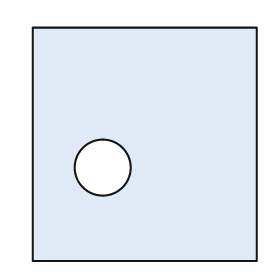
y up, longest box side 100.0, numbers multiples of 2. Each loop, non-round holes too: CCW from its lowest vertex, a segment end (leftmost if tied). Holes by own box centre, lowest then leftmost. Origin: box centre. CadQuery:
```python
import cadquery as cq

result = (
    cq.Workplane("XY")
    .moveTo(-48.0, -50.0)
    .lineTo(48.0, -50.0)
    .lineTo(48.0, 50.0)
    .lineTo(-48.0, 50.0)
    .close()
    .moveTo(-18.0, -10.0)
    .circle(12.0)
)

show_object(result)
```